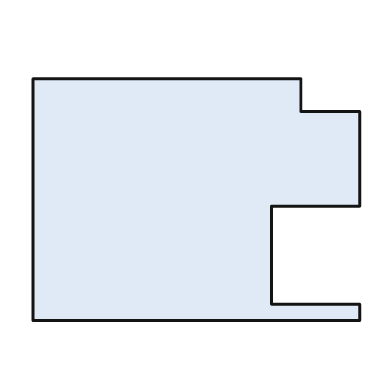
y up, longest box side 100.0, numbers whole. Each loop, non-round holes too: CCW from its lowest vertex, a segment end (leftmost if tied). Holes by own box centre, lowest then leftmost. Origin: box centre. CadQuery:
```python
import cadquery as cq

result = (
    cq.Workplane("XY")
    .moveTo(-50.0, -37.0)
    .lineTo(50.0, -37.0)
    .lineTo(50.0, -32.0)
    .lineTo(23.0, -32.0)
    .lineTo(23.0, -2.0)
    .lineTo(50.0, -2.0)
    .lineTo(50.0, 27.0)
    .lineTo(32.0, 27.0)
    .lineTo(32.0, 37.0)
    .lineTo(-50.0, 37.0)
    .close()
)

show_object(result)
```